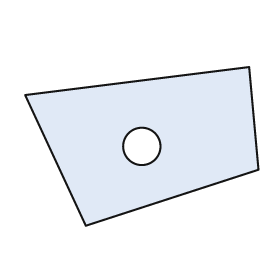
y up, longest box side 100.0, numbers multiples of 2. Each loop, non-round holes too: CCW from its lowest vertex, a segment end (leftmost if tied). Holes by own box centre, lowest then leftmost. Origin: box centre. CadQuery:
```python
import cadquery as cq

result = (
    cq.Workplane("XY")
    .moveTo(-24.0, -34.0)
    .lineTo(50.0, -10.0)
    .lineTo(46.0, 34.0)
    .lineTo(-50.0, 22.0)
    .close()
    .moveTo(0.0, 0.0)
    .circle(8.0)
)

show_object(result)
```